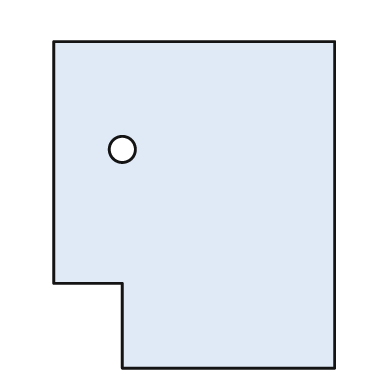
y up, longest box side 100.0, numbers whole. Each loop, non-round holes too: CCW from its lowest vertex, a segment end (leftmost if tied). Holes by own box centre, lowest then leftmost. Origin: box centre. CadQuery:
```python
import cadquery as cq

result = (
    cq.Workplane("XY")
    .moveTo(-22.0, -50.0)
    .lineTo(43.0, -50.0)
    .lineTo(43.0, 50.0)
    .lineTo(-43.0, 50.0)
    .lineTo(-43.0, -24.0)
    .lineTo(-22.0, -24.0)
    .close()
    .moveTo(-22.0, 17.0)
    .circle(4.0)
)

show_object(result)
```